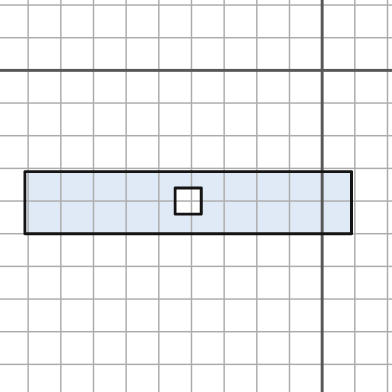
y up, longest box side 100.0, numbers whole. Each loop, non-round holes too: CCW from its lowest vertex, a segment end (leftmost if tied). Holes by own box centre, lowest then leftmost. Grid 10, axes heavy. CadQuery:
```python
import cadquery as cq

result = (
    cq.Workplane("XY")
    .moveTo(-91.0, -50.0)
    .lineTo(9.0, -50.0)
    .lineTo(9.0, -31.0)
    .lineTo(-91.0, -31.0)
    .close()
    .moveTo(-45.0, -44.0)
    .lineTo(-37.0, -44.0)
    .lineTo(-37.0, -36.0)
    .lineTo(-45.0, -36.0)
    .close()
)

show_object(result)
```